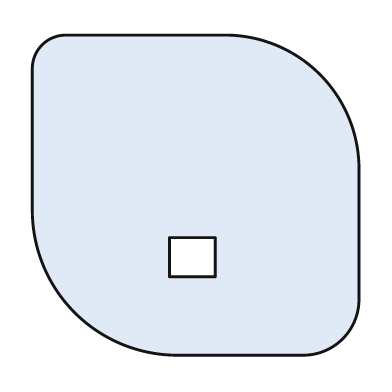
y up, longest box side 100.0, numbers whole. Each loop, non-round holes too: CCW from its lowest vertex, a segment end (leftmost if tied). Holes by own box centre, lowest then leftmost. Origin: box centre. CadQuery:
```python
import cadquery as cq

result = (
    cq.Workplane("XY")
    .moveTo(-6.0, -49.0)
    .lineTo(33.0, -49.0)
    .threePointArc((45.0, -44.0), (50.0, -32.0))
    .lineTo(50.0, 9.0)
    .threePointArc((38.0, 37.0), (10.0, 49.0))
    .lineTo(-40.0, 49.0)
    .threePointArc((-47.0, 46.0), (-50.0, 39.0))
    .lineTo(-50.0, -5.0)
    .threePointArc((-37.0, -36.0), (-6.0, -49.0))
    .close()
    .moveTo(-8.0, -25.0)
    .lineTo(6.0, -25.0)
    .lineTo(6.0, -13.0)
    .lineTo(-8.0, -13.0)
    .close()
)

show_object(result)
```